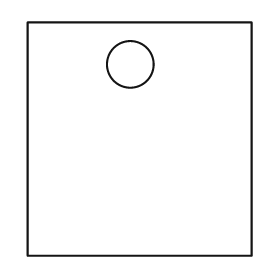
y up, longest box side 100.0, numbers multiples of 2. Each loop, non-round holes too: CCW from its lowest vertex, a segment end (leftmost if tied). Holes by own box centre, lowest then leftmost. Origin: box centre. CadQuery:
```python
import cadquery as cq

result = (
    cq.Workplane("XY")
    .moveTo(-48.0, -50.0)
    .lineTo(48.0, -50.0)
    .lineTo(48.0, 50.0)
    .lineTo(-48.0, 50.0)
    .close()
    .moveTo(-4.0, 32.0)
    .circle(10.0)
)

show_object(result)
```